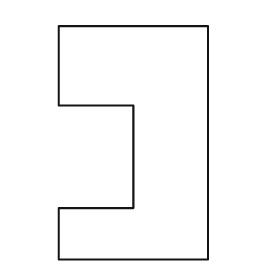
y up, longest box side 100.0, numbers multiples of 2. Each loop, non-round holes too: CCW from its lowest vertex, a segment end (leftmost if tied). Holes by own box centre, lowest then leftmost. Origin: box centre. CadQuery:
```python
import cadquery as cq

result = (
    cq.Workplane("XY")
    .moveTo(-32.0, -50.0)
    .lineTo(32.0, -50.0)
    .lineTo(32.0, 50.0)
    .lineTo(-32.0, 50.0)
    .lineTo(-32.0, 16.0)
    .lineTo(0.0, 16.0)
    .lineTo(0.0, -28.0)
    .lineTo(-32.0, -28.0)
    .close()
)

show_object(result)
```